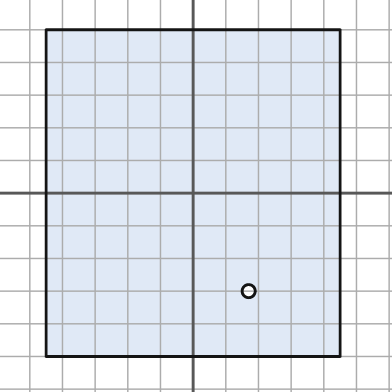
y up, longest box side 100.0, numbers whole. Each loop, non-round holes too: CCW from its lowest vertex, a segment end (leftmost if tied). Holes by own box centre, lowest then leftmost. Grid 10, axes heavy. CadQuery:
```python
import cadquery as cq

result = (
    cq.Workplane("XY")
    .moveTo(-45.0, -50.0)
    .lineTo(45.0, -50.0)
    .lineTo(45.0, 50.0)
    .lineTo(-45.0, 50.0)
    .close()
    .moveTo(17.0, -30.0)
    .circle(2.0)
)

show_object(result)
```